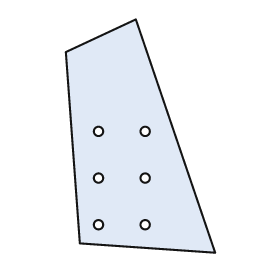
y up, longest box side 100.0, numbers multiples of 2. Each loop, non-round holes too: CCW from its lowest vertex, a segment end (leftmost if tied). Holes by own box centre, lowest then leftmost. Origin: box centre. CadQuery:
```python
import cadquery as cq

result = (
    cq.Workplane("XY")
    .moveTo(32.0, -50.0)
    .lineTo(-2.0, 50.0)
    .lineTo(-32.0, 36.0)
    .lineTo(-26.0, -46.0)
    .close()
    .moveTo(-18.0, -38.0)
    .circle(2.0)
    .moveTo(2.0, -38.0)
    .circle(2.0)
    .moveTo(-18.0, -18.0)
    .circle(2.0)
    .moveTo(2.0, -18.0)
    .circle(2.0)
    .moveTo(-18.0, 2.0)
    .circle(2.0)
    .moveTo(2.0, 2.0)
    .circle(2.0)
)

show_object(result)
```